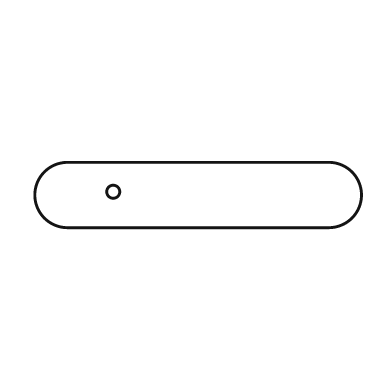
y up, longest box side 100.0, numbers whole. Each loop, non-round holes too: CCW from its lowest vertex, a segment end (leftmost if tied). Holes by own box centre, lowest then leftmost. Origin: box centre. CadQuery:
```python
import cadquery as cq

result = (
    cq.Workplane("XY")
    .moveTo(-40.0, -10.0)
    .lineTo(40.0, -10.0)
    .threePointArc((50.0, 0.0), (40.0, 10.0))
    .lineTo(-40.0, 10.0)
    .threePointArc((-50.0, 0.0), (-40.0, -10.0))
    .close()
    .moveTo(-26.0, 1.0)
    .circle(2.0)
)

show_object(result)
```